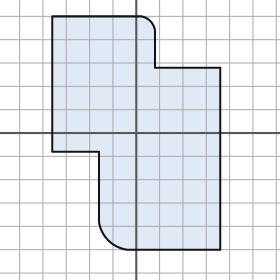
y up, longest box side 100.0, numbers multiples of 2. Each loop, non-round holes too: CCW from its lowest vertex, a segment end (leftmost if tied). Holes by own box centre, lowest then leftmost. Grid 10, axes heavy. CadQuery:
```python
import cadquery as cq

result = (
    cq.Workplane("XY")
    .moveTo(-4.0, -50.0)
    .lineTo(36.0, -50.0)
    .lineTo(36.0, 28.0)
    .lineTo(8.0, 28.0)
    .lineTo(8.0, 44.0)
    .threePointArc((6.0, 48.0), (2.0, 50.0))
    .lineTo(-36.0, 50.0)
    .lineTo(-36.0, -8.0)
    .lineTo(-16.0, -8.0)
    .lineTo(-16.0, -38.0)
    .threePointArc((-12.0, -46.0), (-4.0, -50.0))
    .close()
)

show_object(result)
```